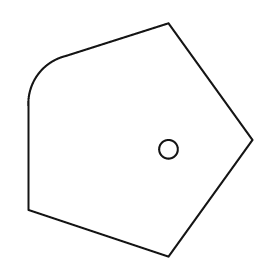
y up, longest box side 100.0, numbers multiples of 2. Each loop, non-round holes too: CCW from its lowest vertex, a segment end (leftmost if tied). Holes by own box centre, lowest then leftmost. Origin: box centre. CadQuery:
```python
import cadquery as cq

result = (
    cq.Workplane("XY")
    .moveTo(12.0, -50.0)
    .lineTo(48.0, 0.0)
    .lineTo(12.0, 50.0)
    .lineTo(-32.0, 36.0)
    .threePointArc((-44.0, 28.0), (-48.0, 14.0))
    .lineTo(-48.0, -30.0)
    .close()
    .moveTo(12.0, -4.0)
    .circle(4.0)
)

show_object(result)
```